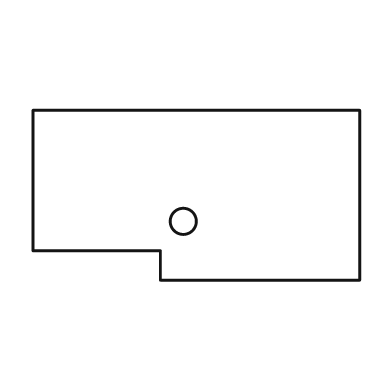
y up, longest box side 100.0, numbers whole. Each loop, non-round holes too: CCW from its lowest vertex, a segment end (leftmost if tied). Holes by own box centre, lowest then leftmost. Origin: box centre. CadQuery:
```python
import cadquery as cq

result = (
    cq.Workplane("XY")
    .moveTo(-11.0, -26.0)
    .lineTo(50.0, -26.0)
    .lineTo(50.0, 26.0)
    .lineTo(-50.0, 26.0)
    .lineTo(-50.0, -17.0)
    .lineTo(-11.0, -17.0)
    .close()
    .moveTo(-4.0, -8.0)
    .circle(4.0)
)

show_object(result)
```